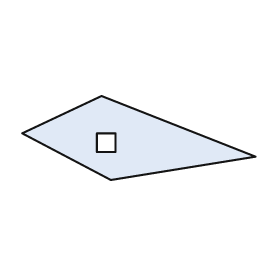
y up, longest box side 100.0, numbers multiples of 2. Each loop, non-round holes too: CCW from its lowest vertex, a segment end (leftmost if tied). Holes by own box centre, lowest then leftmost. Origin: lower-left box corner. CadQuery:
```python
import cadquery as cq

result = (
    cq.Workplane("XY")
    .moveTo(38.0, 0.0)
    .lineTo(100.0, 10.0)
    .lineTo(34.0, 36.0)
    .lineTo(0.0, 20.0)
    .close()
    .moveTo(32.0, 12.0)
    .lineTo(40.0, 12.0)
    .lineTo(40.0, 20.0)
    .lineTo(32.0, 20.0)
    .close()
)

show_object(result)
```